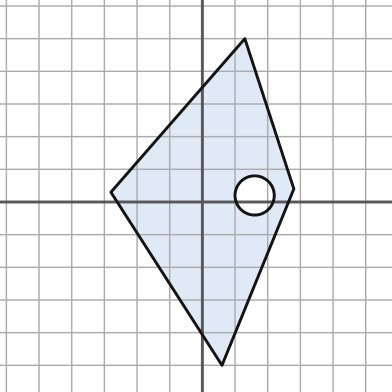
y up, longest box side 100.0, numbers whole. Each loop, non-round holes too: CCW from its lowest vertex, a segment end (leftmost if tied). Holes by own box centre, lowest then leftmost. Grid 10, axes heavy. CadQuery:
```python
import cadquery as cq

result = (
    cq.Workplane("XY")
    .moveTo(6.0, -50.0)
    .lineTo(28.0, 4.0)
    .lineTo(13.0, 50.0)
    .lineTo(-28.0, 3.0)
    .close()
    .moveTo(16.0, 2.0)
    .circle(6.0)
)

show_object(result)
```